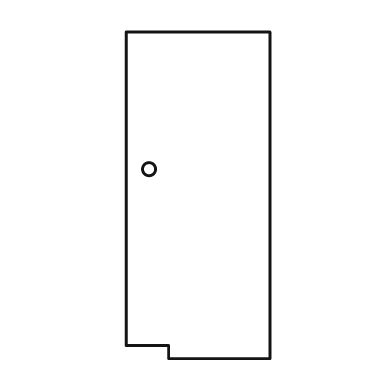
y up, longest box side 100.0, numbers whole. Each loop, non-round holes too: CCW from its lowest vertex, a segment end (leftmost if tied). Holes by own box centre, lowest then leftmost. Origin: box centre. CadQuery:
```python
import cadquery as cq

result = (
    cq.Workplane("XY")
    .moveTo(-9.0, -50.0)
    .lineTo(22.0, -50.0)
    .lineTo(22.0, 50.0)
    .lineTo(-22.0, 50.0)
    .lineTo(-22.0, -46.0)
    .lineTo(-9.0, -46.0)
    .close()
    .moveTo(-15.0, 8.0)
    .circle(2.0)
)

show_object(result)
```